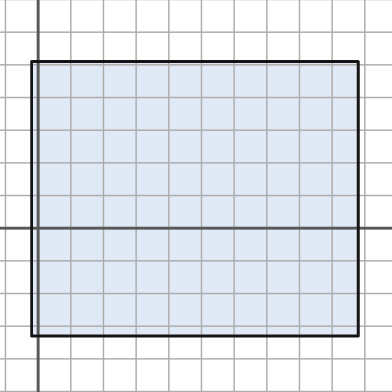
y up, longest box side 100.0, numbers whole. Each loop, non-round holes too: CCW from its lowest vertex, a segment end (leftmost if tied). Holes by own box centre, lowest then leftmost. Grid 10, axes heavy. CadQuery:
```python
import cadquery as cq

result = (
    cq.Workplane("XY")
    .moveTo(-2.0, -33.0)
    .lineTo(98.0, -33.0)
    .lineTo(98.0, 51.0)
    .lineTo(-2.0, 51.0)
    .close()
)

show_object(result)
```